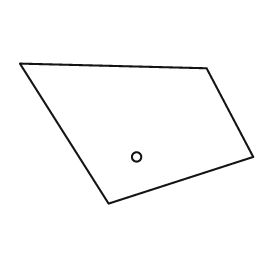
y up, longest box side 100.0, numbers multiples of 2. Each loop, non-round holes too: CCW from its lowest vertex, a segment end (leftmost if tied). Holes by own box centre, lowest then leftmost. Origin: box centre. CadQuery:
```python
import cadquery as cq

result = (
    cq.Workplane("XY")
    .moveTo(-12.0, -30.0)
    .lineTo(50.0, -10.0)
    .lineTo(30.0, 28.0)
    .lineTo(-50.0, 30.0)
    .close()
    .moveTo(0.0, -10.0)
    .circle(2.0)
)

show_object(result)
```